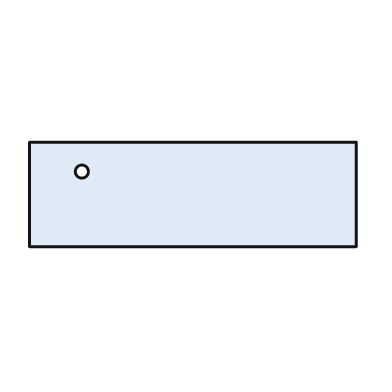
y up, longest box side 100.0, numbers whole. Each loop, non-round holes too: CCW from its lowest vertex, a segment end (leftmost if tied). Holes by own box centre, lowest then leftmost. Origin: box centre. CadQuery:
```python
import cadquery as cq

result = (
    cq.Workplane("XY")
    .moveTo(-50.0, -16.0)
    .lineTo(50.0, -16.0)
    .lineTo(50.0, 16.0)
    .lineTo(-50.0, 16.0)
    .close()
    .moveTo(-34.0, 7.0)
    .circle(2.0)
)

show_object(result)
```